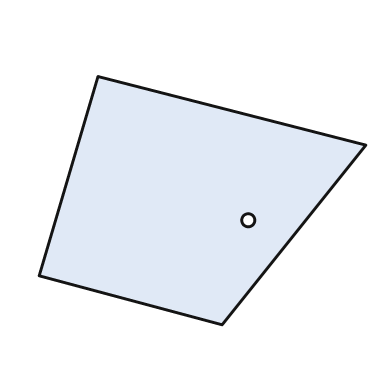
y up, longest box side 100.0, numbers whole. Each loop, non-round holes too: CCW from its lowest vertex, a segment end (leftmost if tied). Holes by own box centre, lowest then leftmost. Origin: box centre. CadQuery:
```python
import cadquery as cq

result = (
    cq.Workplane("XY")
    .moveTo(6.0, -38.0)
    .lineTo(50.0, 17.0)
    .lineTo(-32.0, 38.0)
    .lineTo(-50.0, -23.0)
    .close()
    .moveTo(14.0, -6.0)
    .circle(2.0)
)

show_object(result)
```